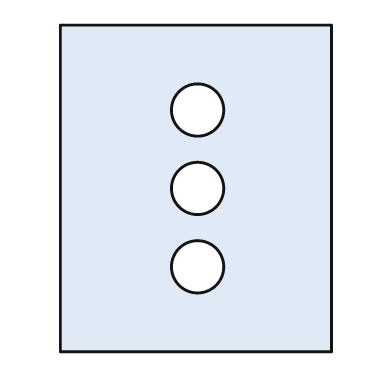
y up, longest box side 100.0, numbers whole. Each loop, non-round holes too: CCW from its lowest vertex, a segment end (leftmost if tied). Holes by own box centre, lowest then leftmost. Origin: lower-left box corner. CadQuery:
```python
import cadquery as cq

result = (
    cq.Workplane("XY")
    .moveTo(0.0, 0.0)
    .lineTo(83.0, 0.0)
    .lineTo(83.0, 100.0)
    .lineTo(0.0, 100.0)
    .close()
    .moveTo(42.0, 26.0)
    .circle(8.0)
    .moveTo(42.0, 50.0)
    .circle(8.0)
    .moveTo(42.0, 74.0)
    .circle(8.0)
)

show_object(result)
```